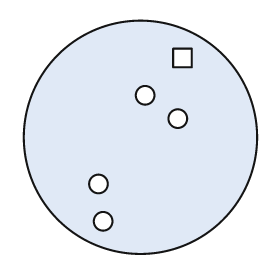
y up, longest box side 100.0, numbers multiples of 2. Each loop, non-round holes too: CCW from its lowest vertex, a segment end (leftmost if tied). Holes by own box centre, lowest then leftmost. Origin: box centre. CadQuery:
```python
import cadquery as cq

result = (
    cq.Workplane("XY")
    .moveTo(0.0, 0.0)
    .circle(50.0)
    .moveTo(-16.0, -36.0)
    .circle(4.0)
    .moveTo(-18.0, -20.0)
    .circle(4.0)
    .moveTo(16.0, 8.0)
    .circle(4.0)
    .moveTo(2.0, 18.0)
    .circle(4.0)
    .moveTo(14.0, 30.0)
    .lineTo(22.0, 30.0)
    .lineTo(22.0, 38.0)
    .lineTo(14.0, 38.0)
    .close()
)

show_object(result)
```